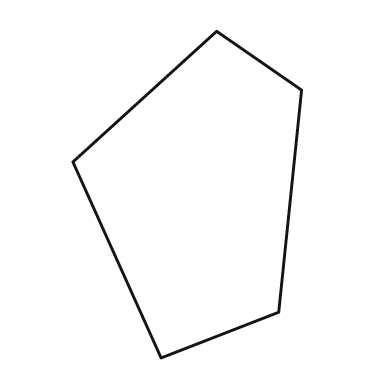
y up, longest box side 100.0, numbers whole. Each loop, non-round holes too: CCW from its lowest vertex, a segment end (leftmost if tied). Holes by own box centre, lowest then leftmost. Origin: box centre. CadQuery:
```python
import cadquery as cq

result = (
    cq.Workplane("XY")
    .moveTo(-8.0, -50.0)
    .lineTo(28.0, -36.0)
    .lineTo(35.0, 32.0)
    .lineTo(9.0, 50.0)
    .lineTo(-35.0, 10.0)
    .close()
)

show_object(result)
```